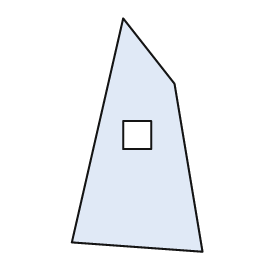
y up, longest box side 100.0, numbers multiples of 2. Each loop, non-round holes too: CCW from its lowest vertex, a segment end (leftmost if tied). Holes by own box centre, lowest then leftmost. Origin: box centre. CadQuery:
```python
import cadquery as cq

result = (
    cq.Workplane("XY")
    .moveTo(28.0, -50.0)
    .lineTo(16.0, 22.0)
    .lineTo(-6.0, 50.0)
    .lineTo(-28.0, -46.0)
    .close()
    .moveTo(-6.0, -6.0)
    .lineTo(6.0, -6.0)
    .lineTo(6.0, 6.0)
    .lineTo(-6.0, 6.0)
    .close()
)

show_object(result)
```